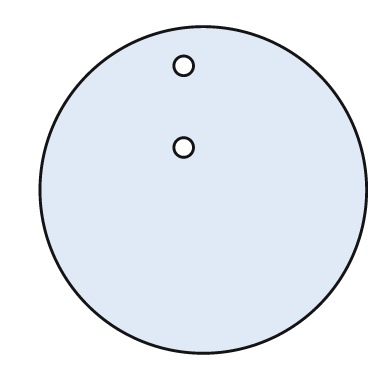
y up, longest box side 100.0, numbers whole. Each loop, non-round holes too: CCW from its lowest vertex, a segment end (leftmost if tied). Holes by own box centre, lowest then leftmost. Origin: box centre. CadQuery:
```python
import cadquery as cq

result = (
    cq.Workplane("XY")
    .moveTo(0.0, 0.0)
    .circle(50.0)
    .moveTo(-6.0, 13.0)
    .circle(3.0)
    .moveTo(-6.0, 38.0)
    .circle(3.0)
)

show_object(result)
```